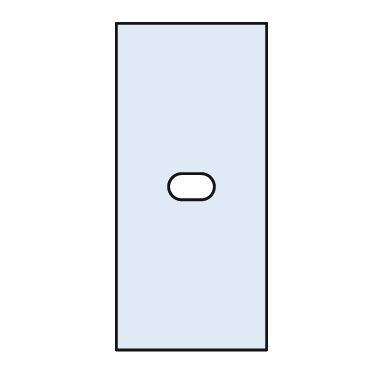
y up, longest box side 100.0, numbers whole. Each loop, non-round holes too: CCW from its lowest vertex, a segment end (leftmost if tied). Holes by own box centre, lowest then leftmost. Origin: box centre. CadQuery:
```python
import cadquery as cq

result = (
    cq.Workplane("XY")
    .moveTo(-23.0, -50.0)
    .lineTo(23.0, -50.0)
    .lineTo(23.0, 50.0)
    .lineTo(-23.0, 50.0)
    .close()
    .moveTo(-3.0, -4.0)
    .lineTo(3.0, -4.0)
    .threePointArc((7.0, 0.0), (3.0, 4.0))
    .lineTo(-3.0, 4.0)
    .threePointArc((-7.0, 0.0), (-3.0, -4.0))
    .close()
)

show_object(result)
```